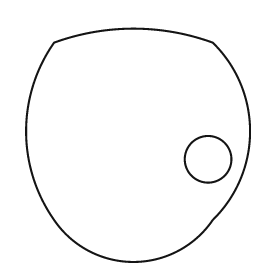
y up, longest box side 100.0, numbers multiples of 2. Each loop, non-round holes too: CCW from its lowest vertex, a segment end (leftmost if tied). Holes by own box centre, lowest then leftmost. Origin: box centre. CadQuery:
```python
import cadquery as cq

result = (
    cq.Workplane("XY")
    .moveTo(-36.0, -32.0)
    .threePointArc((-2.0, -50.0), (32.0, -32.0))
    .threePointArc((48.0, 6.0), (32.0, 44.0))
    .threePointArc((-2.0, 50.0), (-36.0, 44.0))
    .threePointArc((-48.0, 6.0), (-36.0, -32.0))
    .close()
    .moveTo(30.0, -6.0)
    .circle(10.0)
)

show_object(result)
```